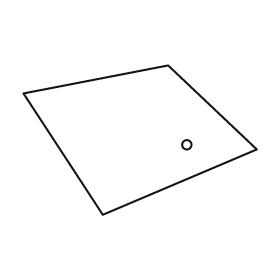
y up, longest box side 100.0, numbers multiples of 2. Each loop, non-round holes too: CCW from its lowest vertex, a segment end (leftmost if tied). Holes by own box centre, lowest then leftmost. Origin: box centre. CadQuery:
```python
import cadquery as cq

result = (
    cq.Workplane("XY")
    .moveTo(-16.0, -32.0)
    .lineTo(50.0, -4.0)
    .lineTo(12.0, 32.0)
    .lineTo(-50.0, 20.0)
    .close()
    .moveTo(20.0, -2.0)
    .circle(2.0)
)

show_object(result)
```